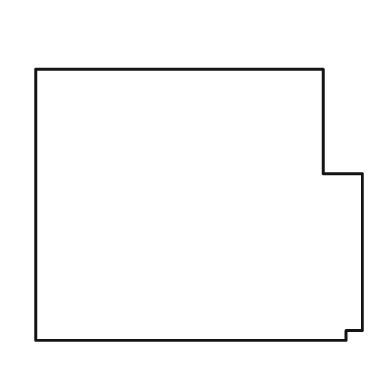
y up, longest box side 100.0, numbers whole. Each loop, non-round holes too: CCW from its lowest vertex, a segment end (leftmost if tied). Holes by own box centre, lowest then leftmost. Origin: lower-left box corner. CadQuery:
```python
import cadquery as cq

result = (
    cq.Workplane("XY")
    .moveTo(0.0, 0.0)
    .lineTo(95.0, 0.0)
    .lineTo(95.0, 3.0)
    .lineTo(100.0, 3.0)
    .lineTo(100.0, 51.0)
    .lineTo(88.0, 51.0)
    .lineTo(88.0, 83.0)
    .lineTo(0.0, 83.0)
    .close()
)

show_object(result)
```